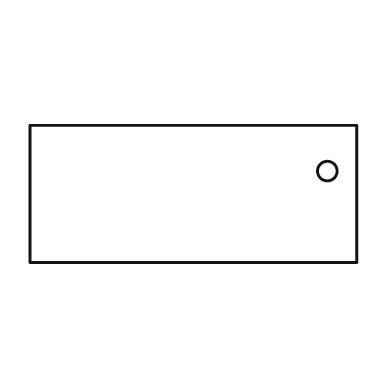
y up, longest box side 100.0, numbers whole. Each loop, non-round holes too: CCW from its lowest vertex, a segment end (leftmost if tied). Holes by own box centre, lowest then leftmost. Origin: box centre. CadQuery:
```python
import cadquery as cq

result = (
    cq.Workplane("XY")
    .moveTo(-50.0, -21.0)
    .lineTo(50.0, -21.0)
    .lineTo(50.0, 21.0)
    .lineTo(-50.0, 21.0)
    .close()
    .moveTo(41.0, 7.0)
    .circle(3.0)
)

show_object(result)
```